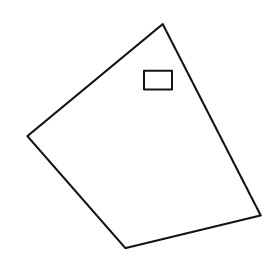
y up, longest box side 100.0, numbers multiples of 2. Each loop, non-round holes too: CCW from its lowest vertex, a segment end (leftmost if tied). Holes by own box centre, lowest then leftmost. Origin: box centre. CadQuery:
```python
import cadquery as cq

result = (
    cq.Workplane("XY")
    .moveTo(-8.0, -48.0)
    .lineTo(50.0, -34.0)
    .lineTo(8.0, 48.0)
    .lineTo(-50.0, 0.0)
    .close()
    .moveTo(0.0, 20.0)
    .lineTo(12.0, 20.0)
    .lineTo(12.0, 28.0)
    .lineTo(0.0, 28.0)
    .close()
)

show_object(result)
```